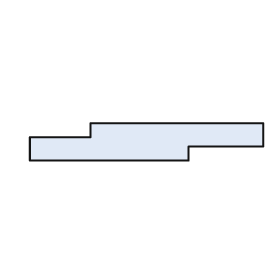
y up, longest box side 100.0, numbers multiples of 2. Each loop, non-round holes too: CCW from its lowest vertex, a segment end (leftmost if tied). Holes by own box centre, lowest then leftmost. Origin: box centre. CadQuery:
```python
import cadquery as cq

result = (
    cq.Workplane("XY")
    .moveTo(-50.0, -8.0)
    .lineTo(18.0, -8.0)
    .lineTo(18.0, -2.0)
    .lineTo(50.0, -2.0)
    .lineTo(50.0, 8.0)
    .lineTo(-24.0, 8.0)
    .lineTo(-24.0, 2.0)
    .lineTo(-50.0, 2.0)
    .close()
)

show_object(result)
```